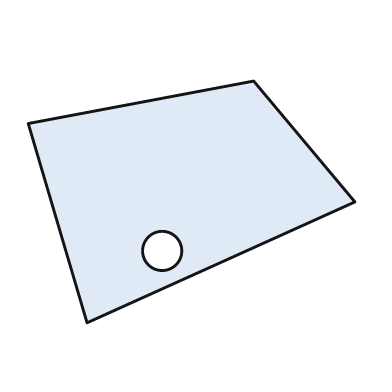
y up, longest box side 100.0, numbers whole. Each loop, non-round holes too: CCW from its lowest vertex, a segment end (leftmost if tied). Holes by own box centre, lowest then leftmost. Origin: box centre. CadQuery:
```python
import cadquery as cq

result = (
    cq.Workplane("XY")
    .moveTo(-32.0, -37.0)
    .lineTo(50.0, 0.0)
    .lineTo(19.0, 37.0)
    .lineTo(-50.0, 24.0)
    .close()
    .moveTo(-9.0, -15.0)
    .circle(6.0)
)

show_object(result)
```